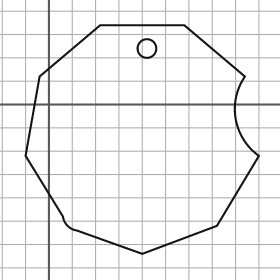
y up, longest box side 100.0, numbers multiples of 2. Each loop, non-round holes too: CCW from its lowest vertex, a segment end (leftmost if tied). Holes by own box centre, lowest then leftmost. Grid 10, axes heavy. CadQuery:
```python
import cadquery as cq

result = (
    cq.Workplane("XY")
    .moveTo(40.0, -64.0)
    .lineTo(72.0, -52.0)
    .lineTo(90.0, -22.0)
    .threePointArc((80.0, -6.0), (84.0, 12.0))
    .lineTo(58.0, 34.0)
    .lineTo(22.0, 34.0)
    .lineTo(-4.0, 12.0)
    .lineTo(-10.0, -22.0)
    .lineTo(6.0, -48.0)
    .threePointArc((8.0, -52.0), (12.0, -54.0))
    .close()
    .moveTo(42.0, 24.0)
    .circle(4.0)
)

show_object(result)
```